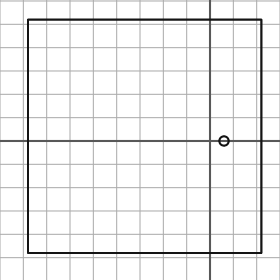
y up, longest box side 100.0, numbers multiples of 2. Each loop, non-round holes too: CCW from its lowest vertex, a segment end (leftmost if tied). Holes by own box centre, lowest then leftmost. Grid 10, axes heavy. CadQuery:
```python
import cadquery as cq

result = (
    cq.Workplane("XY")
    .moveTo(-78.0, -48.0)
    .lineTo(22.0, -48.0)
    .lineTo(22.0, 52.0)
    .lineTo(-78.0, 52.0)
    .close()
    .moveTo(6.0, 0.0)
    .circle(2.0)
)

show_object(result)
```